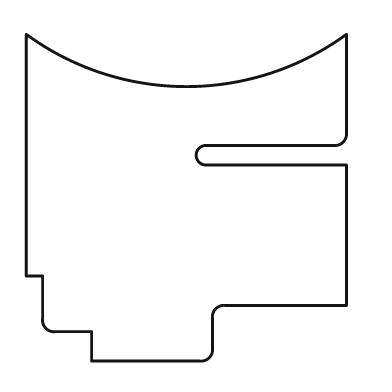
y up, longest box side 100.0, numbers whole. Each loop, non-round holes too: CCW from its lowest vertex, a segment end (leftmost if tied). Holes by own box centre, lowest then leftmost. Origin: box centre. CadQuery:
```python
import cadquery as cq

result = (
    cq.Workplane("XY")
    .moveTo(-29.0, -50.0)
    .lineTo(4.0, -50.0)
    .threePointArc((7.0, -49.0), (8.0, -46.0))
    .lineTo(8.0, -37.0)
    .threePointArc((9.0, -34.0), (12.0, -33.0))
    .lineTo(49.0, -33.0)
    .lineTo(49.0, 10.0)
    .lineTo(6.0, 10.0)
    .threePointArc((3.0, 13.0), (6.0, 16.0))
    .lineTo(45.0, 16.0)
    .threePointArc((48.0, 17.0), (49.0, 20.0))
    .lineTo(49.0, 50.0)
    .threePointArc((0.0, 34.0), (-49.0, 50.0))
    .lineTo(-49.0, -24.0)
    .lineTo(-44.0, -24.0)
    .lineTo(-44.0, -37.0)
    .threePointArc((-43.0, -40.0), (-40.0, -41.0))
    .lineTo(-29.0, -41.0)
    .close()
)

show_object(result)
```